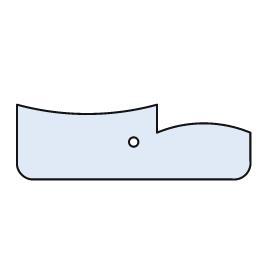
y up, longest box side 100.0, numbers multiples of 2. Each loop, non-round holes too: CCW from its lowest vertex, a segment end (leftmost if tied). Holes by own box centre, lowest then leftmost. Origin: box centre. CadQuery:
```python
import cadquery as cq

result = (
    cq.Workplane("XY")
    .moveTo(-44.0, -16.0)
    .lineTo(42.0, -16.0)
    .threePointArc((48.0, -14.0), (50.0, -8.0))
    .lineTo(50.0, 4.0)
    .threePointArc((30.0, 8.0), (10.0, 4.0))
    .lineTo(10.0, 16.0)
    .threePointArc((-20.0, 12.0), (-50.0, 16.0))
    .lineTo(-50.0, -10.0)
    .threePointArc((-48.0, -14.0), (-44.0, -16.0))
    .close()
    .moveTo(0.0, 0.0)
    .circle(2.0)
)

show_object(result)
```